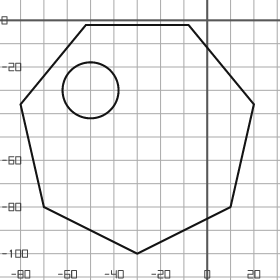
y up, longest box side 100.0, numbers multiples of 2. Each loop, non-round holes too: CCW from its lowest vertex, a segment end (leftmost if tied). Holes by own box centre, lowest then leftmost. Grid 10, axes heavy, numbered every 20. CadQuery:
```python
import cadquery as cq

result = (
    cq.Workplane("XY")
    .moveTo(-30.0, -100.0)
    .lineTo(10.0, -80.0)
    .lineTo(20.0, -36.0)
    .lineTo(-8.0, -2.0)
    .lineTo(-52.0, -2.0)
    .lineTo(-80.0, -36.0)
    .lineTo(-70.0, -80.0)
    .close()
    .moveTo(-50.0, -30.0)
    .circle(12.0)
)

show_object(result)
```